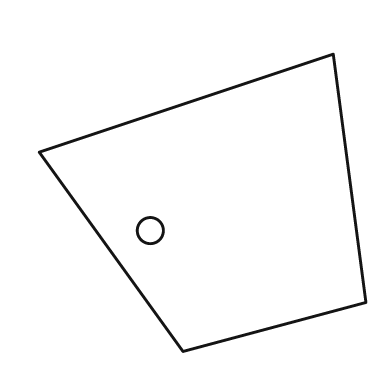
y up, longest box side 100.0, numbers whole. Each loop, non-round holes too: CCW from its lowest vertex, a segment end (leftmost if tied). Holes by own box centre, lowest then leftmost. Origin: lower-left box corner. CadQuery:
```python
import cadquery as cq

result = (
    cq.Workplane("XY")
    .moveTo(44.0, 0.0)
    .lineTo(100.0, 15.0)
    .lineTo(90.0, 91.0)
    .lineTo(0.0, 61.0)
    .close()
    .moveTo(34.0, 37.0)
    .circle(4.0)
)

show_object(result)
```